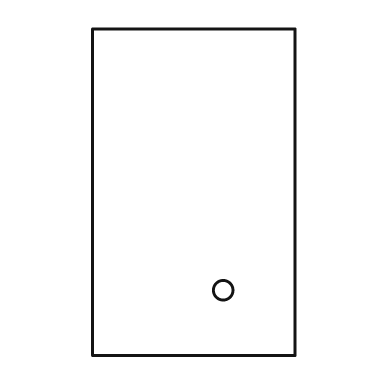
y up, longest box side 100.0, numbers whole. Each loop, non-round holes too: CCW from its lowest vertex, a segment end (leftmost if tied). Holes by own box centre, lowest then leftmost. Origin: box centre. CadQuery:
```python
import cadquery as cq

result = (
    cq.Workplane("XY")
    .moveTo(-31.0, -50.0)
    .lineTo(31.0, -50.0)
    .lineTo(31.0, 50.0)
    .lineTo(-31.0, 50.0)
    .close()
    .moveTo(9.0, -30.0)
    .circle(3.0)
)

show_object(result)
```